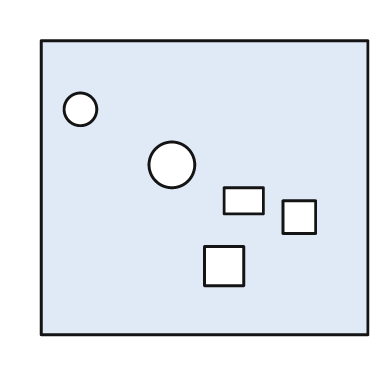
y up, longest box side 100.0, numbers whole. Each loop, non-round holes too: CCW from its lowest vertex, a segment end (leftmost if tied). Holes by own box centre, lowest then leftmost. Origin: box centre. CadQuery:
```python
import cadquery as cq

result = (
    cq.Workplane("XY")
    .moveTo(-50.0, -45.0)
    .lineTo(50.0, -45.0)
    .lineTo(50.0, 45.0)
    .lineTo(-50.0, 45.0)
    .close()
    .moveTo(0.0, -30.0)
    .lineTo(12.0, -30.0)
    .lineTo(12.0, -18.0)
    .lineTo(0.0, -18.0)
    .close()
    .moveTo(24.0, -14.0)
    .lineTo(34.0, -14.0)
    .lineTo(34.0, -4.0)
    .lineTo(24.0, -4.0)
    .close()
    .moveTo(6.0, -8.0)
    .lineTo(18.0, -8.0)
    .lineTo(18.0, 0.0)
    .lineTo(6.0, 0.0)
    .close()
    .moveTo(-10.0, 7.0)
    .circle(7.0)
    .moveTo(-38.0, 24.0)
    .circle(5.0)
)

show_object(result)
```